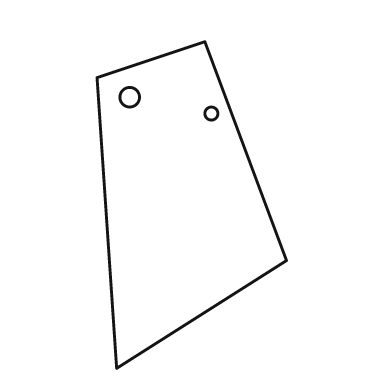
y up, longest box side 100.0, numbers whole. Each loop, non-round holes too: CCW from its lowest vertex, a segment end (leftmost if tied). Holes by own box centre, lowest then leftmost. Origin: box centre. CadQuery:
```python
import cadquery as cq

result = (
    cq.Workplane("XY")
    .moveTo(-23.0, -50.0)
    .lineTo(29.0, -17.0)
    .lineTo(4.0, 50.0)
    .lineTo(-29.0, 39.0)
    .close()
    .moveTo(6.0, 28.0)
    .circle(2.0)
    .moveTo(-19.0, 33.0)
    .circle(3.0)
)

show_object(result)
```